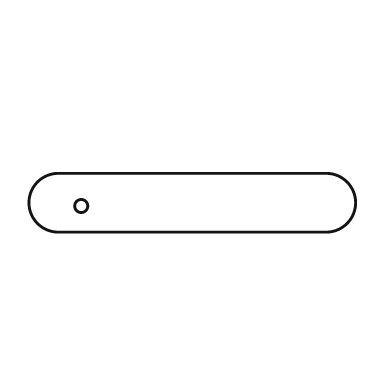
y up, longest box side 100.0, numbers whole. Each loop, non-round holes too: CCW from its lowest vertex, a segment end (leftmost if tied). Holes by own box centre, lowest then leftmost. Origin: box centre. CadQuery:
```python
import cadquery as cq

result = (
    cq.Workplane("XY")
    .moveTo(-41.0, -9.0)
    .lineTo(41.0, -9.0)
    .threePointArc((50.0, 0.0), (41.0, 9.0))
    .lineTo(-41.0, 9.0)
    .threePointArc((-50.0, 0.0), (-41.0, -9.0))
    .close()
    .moveTo(-34.0, -1.0)
    .circle(2.0)
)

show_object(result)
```